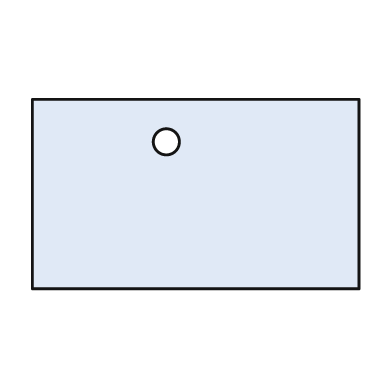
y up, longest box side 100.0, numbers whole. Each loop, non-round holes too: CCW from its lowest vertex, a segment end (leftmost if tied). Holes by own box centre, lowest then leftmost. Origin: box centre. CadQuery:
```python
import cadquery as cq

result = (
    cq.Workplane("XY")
    .moveTo(-50.0, -29.0)
    .lineTo(50.0, -29.0)
    .lineTo(50.0, 29.0)
    .lineTo(-50.0, 29.0)
    .close()
    .moveTo(-9.0, 16.0)
    .circle(4.0)
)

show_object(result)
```